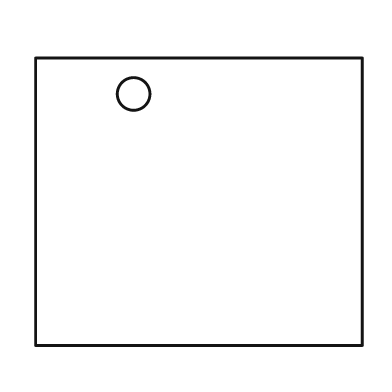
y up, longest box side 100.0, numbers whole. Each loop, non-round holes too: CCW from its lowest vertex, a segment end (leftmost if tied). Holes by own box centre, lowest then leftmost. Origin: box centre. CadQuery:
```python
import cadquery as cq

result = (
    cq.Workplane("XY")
    .moveTo(-50.0, -44.0)
    .lineTo(50.0, -44.0)
    .lineTo(50.0, 44.0)
    .lineTo(-50.0, 44.0)
    .close()
    .moveTo(-20.0, 33.0)
    .circle(5.0)
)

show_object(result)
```